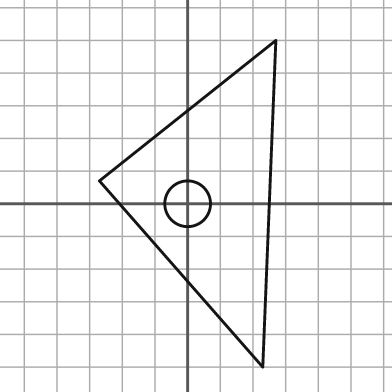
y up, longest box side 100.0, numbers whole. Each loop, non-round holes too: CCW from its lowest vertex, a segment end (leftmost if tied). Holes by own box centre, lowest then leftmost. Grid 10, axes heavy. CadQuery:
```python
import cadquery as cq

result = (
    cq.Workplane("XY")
    .moveTo(23.0, -50.0)
    .lineTo(27.0, 50.0)
    .lineTo(-27.0, 7.0)
    .close()
    .moveTo(0.0, 0.0)
    .circle(7.0)
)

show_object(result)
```